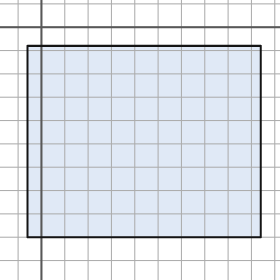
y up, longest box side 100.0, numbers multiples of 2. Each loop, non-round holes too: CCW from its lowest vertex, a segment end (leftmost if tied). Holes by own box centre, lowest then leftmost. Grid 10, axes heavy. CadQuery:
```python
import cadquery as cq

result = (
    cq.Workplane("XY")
    .moveTo(-6.0, -90.0)
    .lineTo(94.0, -90.0)
    .lineTo(94.0, -8.0)
    .lineTo(-6.0, -8.0)
    .close()
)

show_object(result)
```